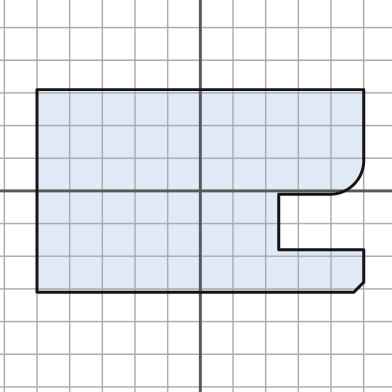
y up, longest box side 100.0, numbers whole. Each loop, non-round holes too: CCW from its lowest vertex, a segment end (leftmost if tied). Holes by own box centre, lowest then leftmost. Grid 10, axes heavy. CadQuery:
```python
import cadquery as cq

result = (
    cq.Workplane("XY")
    .moveTo(-50.0, -31.0)
    .lineTo(47.0, -31.0)
    .lineTo(50.0, -28.0)
    .lineTo(50.0, -18.0)
    .lineTo(24.0, -18.0)
    .lineTo(24.0, -1.0)
    .lineTo(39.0, -1.0)
    .threePointArc((47.0, 2.0), (50.0, 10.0))
    .lineTo(50.0, 31.0)
    .lineTo(-50.0, 31.0)
    .close()
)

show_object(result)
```